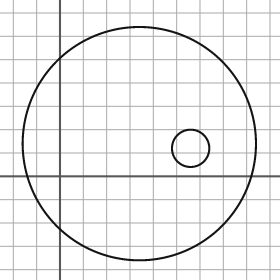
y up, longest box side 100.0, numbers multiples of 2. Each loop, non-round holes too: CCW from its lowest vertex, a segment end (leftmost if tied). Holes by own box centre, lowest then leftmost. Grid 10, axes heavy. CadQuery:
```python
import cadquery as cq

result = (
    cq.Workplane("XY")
    .moveTo(34.0, 14.0)
    .circle(50.0)
    .moveTo(56.0, 12.0)
    .circle(8.0)
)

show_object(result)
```